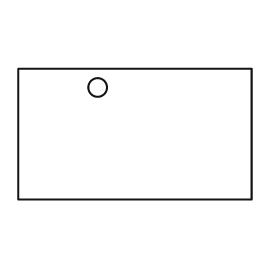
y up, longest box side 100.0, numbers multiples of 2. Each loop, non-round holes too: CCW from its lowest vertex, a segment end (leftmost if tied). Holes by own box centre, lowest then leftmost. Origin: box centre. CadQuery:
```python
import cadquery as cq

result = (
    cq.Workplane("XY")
    .moveTo(-50.0, -28.0)
    .lineTo(50.0, -28.0)
    .lineTo(50.0, 28.0)
    .lineTo(-50.0, 28.0)
    .close()
    .moveTo(-16.0, 20.0)
    .circle(4.0)
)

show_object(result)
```